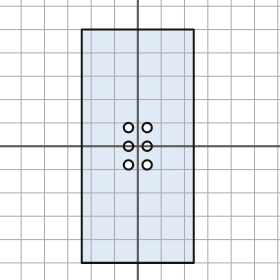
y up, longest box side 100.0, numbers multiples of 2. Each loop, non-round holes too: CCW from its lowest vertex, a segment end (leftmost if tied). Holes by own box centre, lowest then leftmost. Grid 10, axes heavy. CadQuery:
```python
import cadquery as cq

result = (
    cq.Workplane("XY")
    .moveTo(-24.0, -50.0)
    .lineTo(24.0, -50.0)
    .lineTo(24.0, 50.0)
    .lineTo(-24.0, 50.0)
    .close()
    .moveTo(-4.0, -8.0)
    .circle(2.0)
    .moveTo(4.0, -8.0)
    .circle(2.0)
    .moveTo(-4.0, 0.0)
    .circle(2.0)
    .moveTo(4.0, 0.0)
    .circle(2.0)
    .moveTo(-4.0, 8.0)
    .circle(2.0)
    .moveTo(4.0, 8.0)
    .circle(2.0)
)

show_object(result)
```